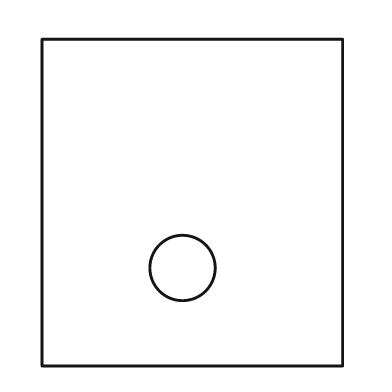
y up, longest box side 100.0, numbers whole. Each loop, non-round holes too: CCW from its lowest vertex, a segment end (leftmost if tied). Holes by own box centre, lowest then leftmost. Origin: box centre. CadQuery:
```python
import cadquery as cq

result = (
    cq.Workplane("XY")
    .moveTo(-46.0, -50.0)
    .lineTo(46.0, -50.0)
    .lineTo(46.0, 50.0)
    .lineTo(-46.0, 50.0)
    .close()
    .moveTo(-3.0, -20.0)
    .circle(10.0)
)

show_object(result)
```